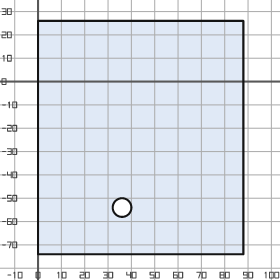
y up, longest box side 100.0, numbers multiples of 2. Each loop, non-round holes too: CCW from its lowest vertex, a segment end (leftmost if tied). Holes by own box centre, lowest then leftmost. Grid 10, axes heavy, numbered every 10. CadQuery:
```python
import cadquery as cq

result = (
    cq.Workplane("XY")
    .moveTo(0.0, -74.0)
    .lineTo(88.0, -74.0)
    .lineTo(88.0, 26.0)
    .lineTo(0.0, 26.0)
    .close()
    .moveTo(36.0, -54.0)
    .circle(4.0)
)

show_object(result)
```